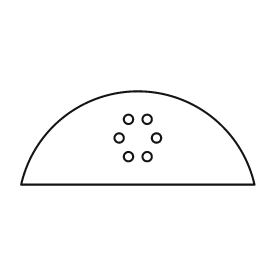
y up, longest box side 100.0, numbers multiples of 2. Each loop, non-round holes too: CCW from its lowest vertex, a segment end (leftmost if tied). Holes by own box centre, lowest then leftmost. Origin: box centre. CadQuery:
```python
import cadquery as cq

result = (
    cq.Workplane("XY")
    .moveTo(-50.0, -20.0)
    .lineTo(50.0, -20.0)
    .threePointArc((0.0, 20.0), (-50.0, -20.0))
    .close()
    .moveTo(-4.0, -8.0)
    .circle(2.0)
    .moveTo(4.0, -8.0)
    .circle(2.0)
    .moveTo(-8.0, 0.0)
    .circle(2.0)
    .moveTo(8.0, 0.0)
    .circle(2.0)
    .moveTo(-4.0, 8.0)
    .circle(2.0)
    .moveTo(4.0, 8.0)
    .circle(2.0)
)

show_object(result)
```